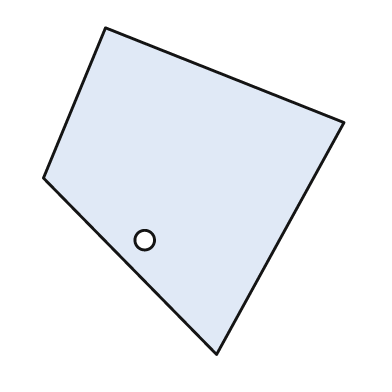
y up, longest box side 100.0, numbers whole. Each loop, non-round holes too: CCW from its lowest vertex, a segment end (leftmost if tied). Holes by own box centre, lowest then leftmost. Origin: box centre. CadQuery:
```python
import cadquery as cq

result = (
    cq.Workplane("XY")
    .moveTo(7.0, -50.0)
    .lineTo(46.0, 21.0)
    .lineTo(-27.0, 50.0)
    .lineTo(-46.0, 4.0)
    .close()
    .moveTo(-15.0, -15.0)
    .circle(3.0)
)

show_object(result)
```